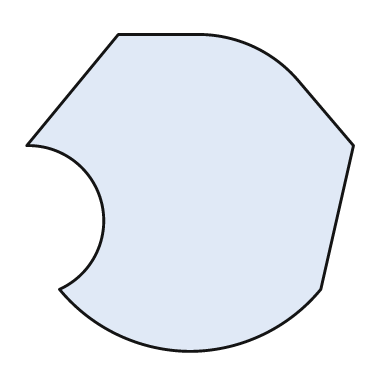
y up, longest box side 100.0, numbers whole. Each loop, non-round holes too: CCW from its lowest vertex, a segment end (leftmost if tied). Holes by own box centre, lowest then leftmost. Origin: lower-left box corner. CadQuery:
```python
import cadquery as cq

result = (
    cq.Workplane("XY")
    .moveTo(50.0, 0.0)
    .threePointArc((72.0, 5.0), (90.0, 19.0))
    .lineTo(100.0, 63.0)
    .lineTo(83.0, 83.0)
    .threePointArc((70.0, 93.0), (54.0, 97.0))
    .lineTo(28.0, 97.0)
    .lineTo(0.0, 63.0)
    .threePointArc((23.0, 45.0), (10.0, 19.0))
    .threePointArc((28.0, 5.0), (50.0, 0.0))
    .close()
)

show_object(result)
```